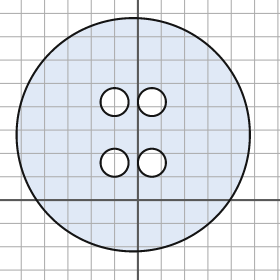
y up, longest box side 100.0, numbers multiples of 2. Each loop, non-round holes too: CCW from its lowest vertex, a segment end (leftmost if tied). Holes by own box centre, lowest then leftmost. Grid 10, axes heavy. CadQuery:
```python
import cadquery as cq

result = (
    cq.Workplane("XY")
    .moveTo(-2.0, 28.0)
    .circle(50.0)
    .moveTo(-10.0, 16.0)
    .circle(6.0)
    .moveTo(6.0, 16.0)
    .circle(6.0)
    .moveTo(-10.0, 42.0)
    .circle(6.0)
    .moveTo(6.0, 42.0)
    .circle(6.0)
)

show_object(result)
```